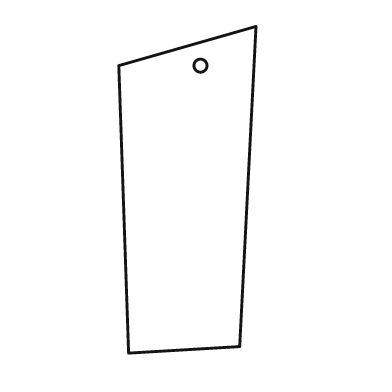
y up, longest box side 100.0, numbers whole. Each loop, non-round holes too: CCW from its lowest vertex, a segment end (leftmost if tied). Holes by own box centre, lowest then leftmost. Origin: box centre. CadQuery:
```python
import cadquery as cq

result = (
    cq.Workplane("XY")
    .moveTo(-18.0, -50.0)
    .lineTo(16.0, -48.0)
    .lineTo(21.0, 50.0)
    .lineTo(-21.0, 38.0)
    .close()
    .moveTo(4.0, 38.0)
    .circle(2.0)
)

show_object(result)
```